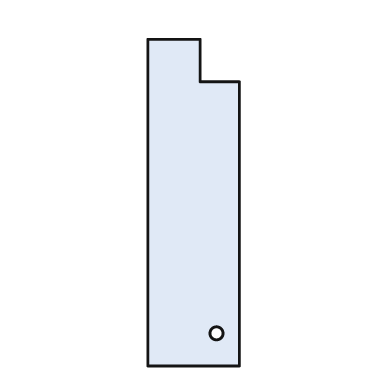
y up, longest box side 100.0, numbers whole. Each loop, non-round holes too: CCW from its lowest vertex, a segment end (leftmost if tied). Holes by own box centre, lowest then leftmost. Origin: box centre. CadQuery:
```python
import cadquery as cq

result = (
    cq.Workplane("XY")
    .moveTo(-14.0, -50.0)
    .lineTo(14.0, -50.0)
    .lineTo(14.0, 37.0)
    .lineTo(2.0, 37.0)
    .lineTo(2.0, 50.0)
    .lineTo(-14.0, 50.0)
    .close()
    .moveTo(7.0, -40.0)
    .circle(2.0)
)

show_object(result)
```